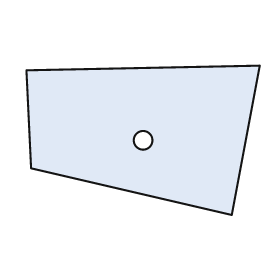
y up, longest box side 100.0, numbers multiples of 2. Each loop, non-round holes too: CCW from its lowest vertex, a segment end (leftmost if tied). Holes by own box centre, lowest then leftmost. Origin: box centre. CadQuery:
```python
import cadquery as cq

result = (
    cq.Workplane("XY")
    .moveTo(38.0, -32.0)
    .lineTo(50.0, 32.0)
    .lineTo(-50.0, 30.0)
    .lineTo(-48.0, -12.0)
    .close()
    .moveTo(0.0, 0.0)
    .circle(4.0)
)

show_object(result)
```